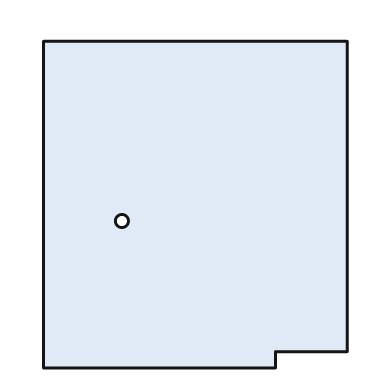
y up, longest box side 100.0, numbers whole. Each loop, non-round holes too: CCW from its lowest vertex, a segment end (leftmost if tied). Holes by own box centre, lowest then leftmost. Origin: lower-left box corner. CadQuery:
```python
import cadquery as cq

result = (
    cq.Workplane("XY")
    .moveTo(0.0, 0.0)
    .lineTo(71.0, 0.0)
    .lineTo(71.0, 5.0)
    .lineTo(93.0, 5.0)
    .lineTo(93.0, 100.0)
    .lineTo(0.0, 100.0)
    .close()
    .moveTo(24.0, 45.0)
    .circle(2.0)
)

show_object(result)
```